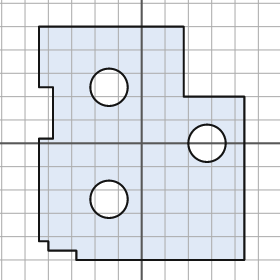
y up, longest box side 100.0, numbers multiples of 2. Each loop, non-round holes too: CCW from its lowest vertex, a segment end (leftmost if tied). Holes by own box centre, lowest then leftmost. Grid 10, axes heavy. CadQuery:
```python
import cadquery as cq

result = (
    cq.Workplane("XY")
    .moveTo(-28.0, -50.0)
    .lineTo(44.0, -50.0)
    .lineTo(44.0, 20.0)
    .lineTo(18.0, 20.0)
    .lineTo(18.0, 50.0)
    .lineTo(-44.0, 50.0)
    .lineTo(-44.0, 24.0)
    .lineTo(-38.0, 24.0)
    .lineTo(-38.0, 2.0)
    .lineTo(-44.0, 2.0)
    .lineTo(-44.0, -42.0)
    .lineTo(-40.0, -42.0)
    .lineTo(-40.0, -46.0)
    .lineTo(-28.0, -46.0)
    .close()
    .moveTo(-14.0, -24.0)
    .circle(8.0)
    .moveTo(28.0, 0.0)
    .circle(8.0)
    .moveTo(-14.0, 24.0)
    .circle(8.0)
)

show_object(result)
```